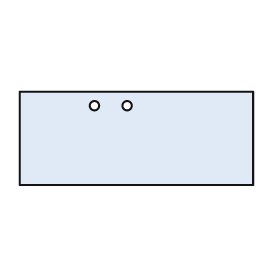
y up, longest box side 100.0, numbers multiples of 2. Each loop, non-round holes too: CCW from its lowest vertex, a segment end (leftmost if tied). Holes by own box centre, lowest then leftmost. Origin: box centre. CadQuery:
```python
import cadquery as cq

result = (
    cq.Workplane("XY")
    .moveTo(-50.0, -20.0)
    .lineTo(50.0, -20.0)
    .lineTo(50.0, 20.0)
    .lineTo(-50.0, 20.0)
    .close()
    .moveTo(-18.0, 14.0)
    .circle(2.0)
    .moveTo(-4.0, 14.0)
    .circle(2.0)
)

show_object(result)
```